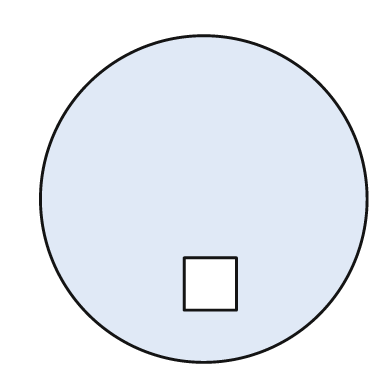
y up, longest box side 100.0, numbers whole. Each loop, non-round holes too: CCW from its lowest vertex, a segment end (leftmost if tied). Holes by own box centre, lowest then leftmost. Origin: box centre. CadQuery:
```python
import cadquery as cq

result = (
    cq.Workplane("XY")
    .moveTo(0.0, 0.0)
    .circle(50.0)
    .moveTo(-6.0, -34.0)
    .lineTo(10.0, -34.0)
    .lineTo(10.0, -18.0)
    .lineTo(-6.0, -18.0)
    .close()
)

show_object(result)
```